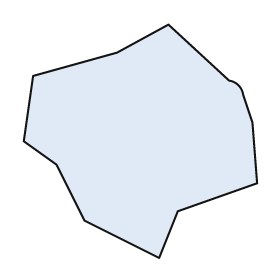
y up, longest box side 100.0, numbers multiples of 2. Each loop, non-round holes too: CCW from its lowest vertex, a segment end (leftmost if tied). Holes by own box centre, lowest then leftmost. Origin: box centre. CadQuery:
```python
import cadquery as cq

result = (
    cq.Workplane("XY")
    .moveTo(8.0, -50.0)
    .lineTo(16.0, -30.0)
    .lineTo(50.0, -18.0)
    .lineTo(48.0, 8.0)
    .lineTo(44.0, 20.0)
    .threePointArc((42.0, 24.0), (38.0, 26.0))
    .lineTo(12.0, 50.0)
    .lineTo(-10.0, 38.0)
    .lineTo(-46.0, 28.0)
    .lineTo(-50.0, 0.0)
    .lineTo(-36.0, -10.0)
    .lineTo(-24.0, -34.0)
    .close()
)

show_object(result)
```